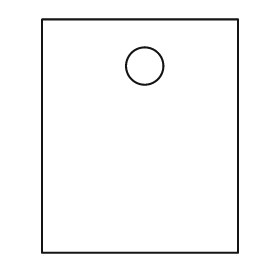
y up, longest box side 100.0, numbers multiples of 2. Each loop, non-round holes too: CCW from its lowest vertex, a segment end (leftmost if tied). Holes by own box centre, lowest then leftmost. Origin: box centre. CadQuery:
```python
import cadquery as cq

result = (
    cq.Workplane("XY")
    .moveTo(-42.0, -50.0)
    .lineTo(42.0, -50.0)
    .lineTo(42.0, 50.0)
    .lineTo(-42.0, 50.0)
    .close()
    .moveTo(2.0, 30.0)
    .circle(8.0)
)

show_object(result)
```